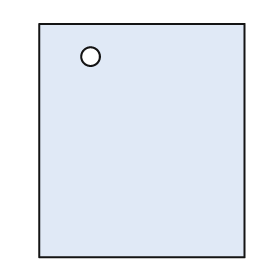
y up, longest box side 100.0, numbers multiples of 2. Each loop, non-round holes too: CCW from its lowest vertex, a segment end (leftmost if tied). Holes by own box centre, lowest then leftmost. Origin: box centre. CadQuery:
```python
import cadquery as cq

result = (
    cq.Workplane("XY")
    .moveTo(-44.0, -50.0)
    .lineTo(44.0, -50.0)
    .lineTo(44.0, 50.0)
    .lineTo(-44.0, 50.0)
    .close()
    .moveTo(-22.0, 36.0)
    .circle(4.0)
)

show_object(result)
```